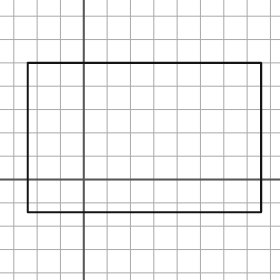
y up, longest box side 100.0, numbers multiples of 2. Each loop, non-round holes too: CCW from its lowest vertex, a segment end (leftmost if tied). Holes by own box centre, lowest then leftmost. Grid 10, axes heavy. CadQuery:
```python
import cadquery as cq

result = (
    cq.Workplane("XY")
    .moveTo(-24.0, -14.0)
    .lineTo(76.0, -14.0)
    .lineTo(76.0, 50.0)
    .lineTo(-24.0, 50.0)
    .close()
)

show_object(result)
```